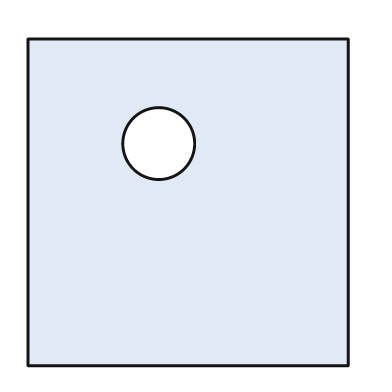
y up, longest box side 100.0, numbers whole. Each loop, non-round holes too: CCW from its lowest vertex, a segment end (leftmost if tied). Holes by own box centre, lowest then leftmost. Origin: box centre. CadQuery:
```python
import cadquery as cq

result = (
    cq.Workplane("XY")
    .moveTo(-49.0, -50.0)
    .lineTo(49.0, -50.0)
    .lineTo(49.0, 50.0)
    .lineTo(-49.0, 50.0)
    .close()
    .moveTo(-9.0, 18.0)
    .circle(11.0)
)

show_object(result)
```